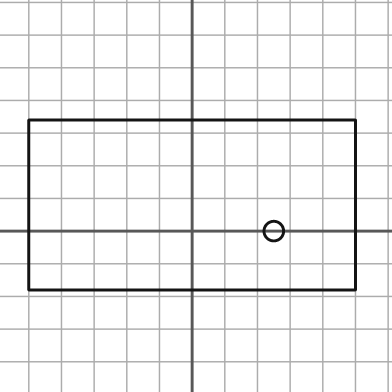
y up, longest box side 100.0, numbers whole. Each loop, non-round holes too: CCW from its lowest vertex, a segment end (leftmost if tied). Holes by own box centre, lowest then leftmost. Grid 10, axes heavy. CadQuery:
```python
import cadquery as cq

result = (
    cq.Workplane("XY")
    .moveTo(-50.0, -18.0)
    .lineTo(50.0, -18.0)
    .lineTo(50.0, 34.0)
    .lineTo(-50.0, 34.0)
    .close()
    .moveTo(25.0, 0.0)
    .circle(3.0)
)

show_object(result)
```